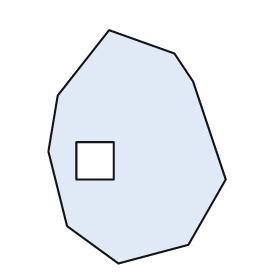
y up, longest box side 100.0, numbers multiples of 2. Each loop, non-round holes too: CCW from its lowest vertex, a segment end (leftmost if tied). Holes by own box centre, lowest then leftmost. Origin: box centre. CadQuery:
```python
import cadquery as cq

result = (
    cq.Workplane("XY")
    .moveTo(-8.0, -50.0)
    .lineTo(22.0, -42.0)
    .lineTo(38.0, -14.0)
    .lineTo(24.0, 28.0)
    .lineTo(16.0, 40.0)
    .lineTo(-12.0, 50.0)
    .lineTo(-34.0, 22.0)
    .lineTo(-38.0, -2.0)
    .lineTo(-30.0, -34.0)
    .close()
    .moveTo(-26.0, -14.0)
    .lineTo(-10.0, -14.0)
    .lineTo(-10.0, 2.0)
    .lineTo(-26.0, 2.0)
    .close()
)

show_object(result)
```